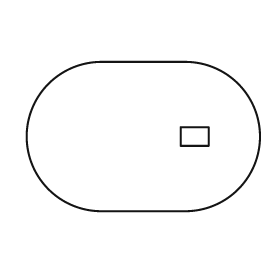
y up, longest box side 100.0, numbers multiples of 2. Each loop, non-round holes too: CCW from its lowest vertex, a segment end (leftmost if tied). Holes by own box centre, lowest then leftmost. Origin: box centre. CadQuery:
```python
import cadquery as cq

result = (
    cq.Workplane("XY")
    .moveTo(-18.0, -32.0)
    .lineTo(18.0, -32.0)
    .threePointArc((50.0, 0.0), (18.0, 32.0))
    .lineTo(-18.0, 32.0)
    .threePointArc((-50.0, 0.0), (-18.0, -32.0))
    .close()
    .moveTo(16.0, -4.0)
    .lineTo(28.0, -4.0)
    .lineTo(28.0, 4.0)
    .lineTo(16.0, 4.0)
    .close()
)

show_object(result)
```